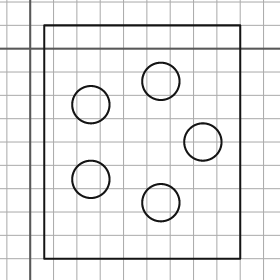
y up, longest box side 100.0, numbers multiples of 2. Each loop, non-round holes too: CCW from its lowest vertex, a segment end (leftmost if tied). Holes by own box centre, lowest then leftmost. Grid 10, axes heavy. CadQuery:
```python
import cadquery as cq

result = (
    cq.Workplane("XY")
    .moveTo(6.0, -90.0)
    .lineTo(90.0, -90.0)
    .lineTo(90.0, 10.0)
    .lineTo(6.0, 10.0)
    .close()
    .moveTo(56.0, -66.0)
    .circle(8.0)
    .moveTo(26.0, -56.0)
    .circle(8.0)
    .moveTo(74.0, -40.0)
    .circle(8.0)
    .moveTo(26.0, -24.0)
    .circle(8.0)
    .moveTo(56.0, -14.0)
    .circle(8.0)
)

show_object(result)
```